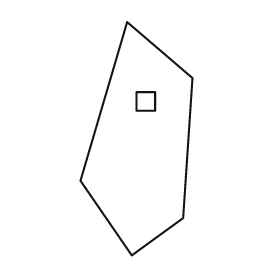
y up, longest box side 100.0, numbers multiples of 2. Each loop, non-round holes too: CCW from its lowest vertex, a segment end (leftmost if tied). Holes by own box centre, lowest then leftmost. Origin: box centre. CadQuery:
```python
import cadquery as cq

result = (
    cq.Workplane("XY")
    .moveTo(-2.0, -50.0)
    .lineTo(20.0, -34.0)
    .lineTo(24.0, 26.0)
    .lineTo(-4.0, 50.0)
    .lineTo(-24.0, -18.0)
    .close()
    .moveTo(0.0, 12.0)
    .lineTo(8.0, 12.0)
    .lineTo(8.0, 20.0)
    .lineTo(0.0, 20.0)
    .close()
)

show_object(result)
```